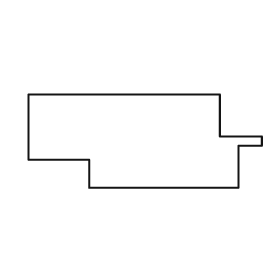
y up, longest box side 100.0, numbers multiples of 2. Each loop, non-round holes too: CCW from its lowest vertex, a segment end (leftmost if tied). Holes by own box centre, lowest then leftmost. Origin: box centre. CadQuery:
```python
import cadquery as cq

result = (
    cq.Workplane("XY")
    .moveTo(-24.0, -20.0)
    .lineTo(40.0, -20.0)
    .lineTo(40.0, -2.0)
    .lineTo(50.0, -2.0)
    .lineTo(50.0, 2.0)
    .lineTo(32.0, 2.0)
    .lineTo(32.0, 20.0)
    .lineTo(-50.0, 20.0)
    .lineTo(-50.0, -8.0)
    .lineTo(-24.0, -8.0)
    .close()
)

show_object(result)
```